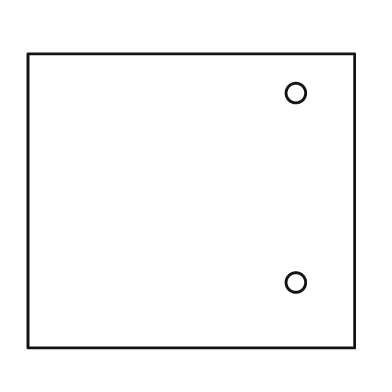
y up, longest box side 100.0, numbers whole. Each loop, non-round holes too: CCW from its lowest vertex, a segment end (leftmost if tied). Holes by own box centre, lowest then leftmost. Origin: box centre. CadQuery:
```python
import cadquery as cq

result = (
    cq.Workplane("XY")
    .moveTo(-50.0, -45.0)
    .lineTo(50.0, -45.0)
    .lineTo(50.0, 45.0)
    .lineTo(-50.0, 45.0)
    .close()
    .moveTo(32.0, -25.0)
    .circle(3.0)
    .moveTo(32.0, 33.0)
    .circle(3.0)
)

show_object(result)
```